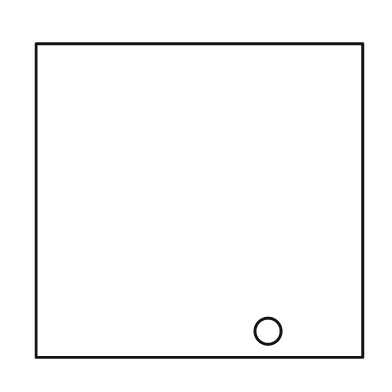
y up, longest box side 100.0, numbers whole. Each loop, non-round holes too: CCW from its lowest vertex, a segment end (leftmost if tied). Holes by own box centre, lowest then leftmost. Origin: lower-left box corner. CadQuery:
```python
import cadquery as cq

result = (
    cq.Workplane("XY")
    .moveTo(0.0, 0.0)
    .lineTo(100.0, 0.0)
    .lineTo(100.0, 96.0)
    .lineTo(0.0, 96.0)
    .close()
    .moveTo(71.0, 8.0)
    .circle(4.0)
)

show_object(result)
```